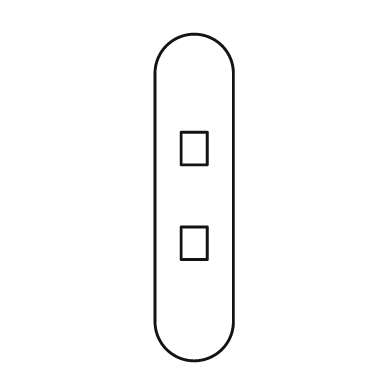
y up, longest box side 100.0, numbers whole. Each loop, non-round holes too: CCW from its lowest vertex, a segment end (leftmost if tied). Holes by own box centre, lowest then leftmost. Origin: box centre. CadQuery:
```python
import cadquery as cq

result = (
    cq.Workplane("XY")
    .moveTo(-12.0, -38.0)
    .threePointArc((0.0, -50.0), (12.0, -38.0))
    .lineTo(12.0, 38.0)
    .threePointArc((0.0, 50.0), (-12.0, 38.0))
    .close()
    .moveTo(-4.0, -19.0)
    .lineTo(4.0, -19.0)
    .lineTo(4.0, -9.0)
    .lineTo(-4.0, -9.0)
    .close()
    .moveTo(-4.0, 10.0)
    .lineTo(4.0, 10.0)
    .lineTo(4.0, 20.0)
    .lineTo(-4.0, 20.0)
    .close()
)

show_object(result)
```